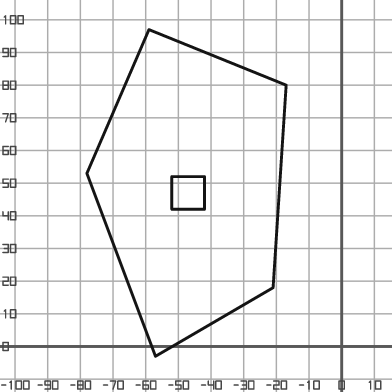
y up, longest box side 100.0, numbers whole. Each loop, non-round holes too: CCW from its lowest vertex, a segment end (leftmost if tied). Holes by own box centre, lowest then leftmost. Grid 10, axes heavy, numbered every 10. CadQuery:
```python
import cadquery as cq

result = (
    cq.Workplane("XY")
    .moveTo(-57.0, -3.0)
    .lineTo(-21.0, 18.0)
    .lineTo(-17.0, 80.0)
    .lineTo(-59.0, 97.0)
    .lineTo(-78.0, 53.0)
    .close()
    .moveTo(-52.0, 42.0)
    .lineTo(-42.0, 42.0)
    .lineTo(-42.0, 52.0)
    .lineTo(-52.0, 52.0)
    .close()
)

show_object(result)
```